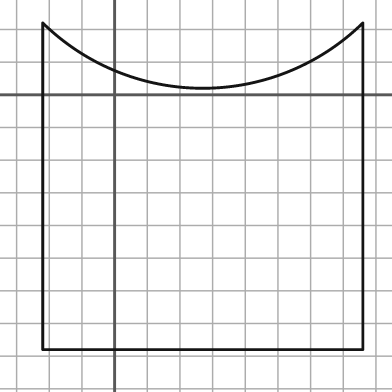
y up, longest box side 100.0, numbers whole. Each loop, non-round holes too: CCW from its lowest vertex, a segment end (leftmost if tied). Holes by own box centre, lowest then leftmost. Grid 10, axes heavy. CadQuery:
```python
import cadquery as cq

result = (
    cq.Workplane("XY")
    .moveTo(-22.0, -78.0)
    .lineTo(76.0, -78.0)
    .lineTo(76.0, 22.0)
    .threePointArc((27.0, 2.0), (-22.0, 22.0))
    .close()
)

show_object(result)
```